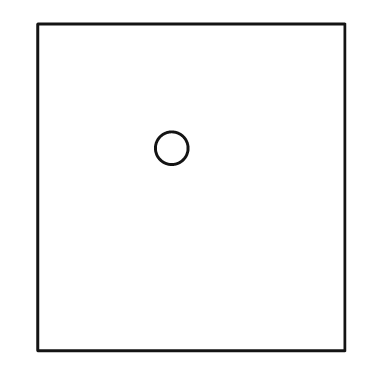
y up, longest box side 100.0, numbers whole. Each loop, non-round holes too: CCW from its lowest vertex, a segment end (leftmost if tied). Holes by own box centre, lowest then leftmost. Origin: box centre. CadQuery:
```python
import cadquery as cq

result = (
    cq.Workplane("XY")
    .moveTo(-47.0, -50.0)
    .lineTo(47.0, -50.0)
    .lineTo(47.0, 50.0)
    .lineTo(-47.0, 50.0)
    .close()
    .moveTo(-6.0, 12.0)
    .circle(5.0)
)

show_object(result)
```